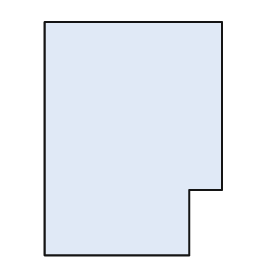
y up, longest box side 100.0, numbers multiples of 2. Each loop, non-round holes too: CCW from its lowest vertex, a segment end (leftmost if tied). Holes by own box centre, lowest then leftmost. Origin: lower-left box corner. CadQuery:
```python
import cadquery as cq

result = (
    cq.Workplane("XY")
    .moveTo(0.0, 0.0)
    .lineTo(62.0, 0.0)
    .lineTo(62.0, 28.0)
    .lineTo(76.0, 28.0)
    .lineTo(76.0, 100.0)
    .lineTo(0.0, 100.0)
    .close()
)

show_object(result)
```